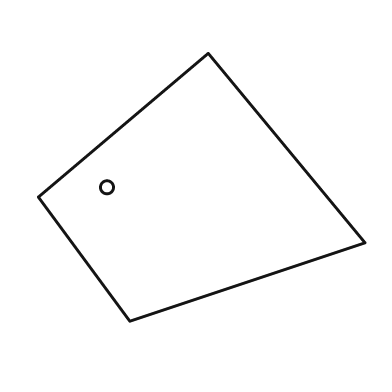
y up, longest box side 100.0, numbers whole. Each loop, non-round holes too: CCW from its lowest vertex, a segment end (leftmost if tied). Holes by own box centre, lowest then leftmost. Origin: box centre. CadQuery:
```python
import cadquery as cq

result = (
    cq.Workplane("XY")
    .moveTo(-22.0, -41.0)
    .lineTo(50.0, -17.0)
    .lineTo(2.0, 41.0)
    .lineTo(-50.0, -3.0)
    .close()
    .moveTo(-29.0, 0.0)
    .circle(2.0)
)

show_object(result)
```